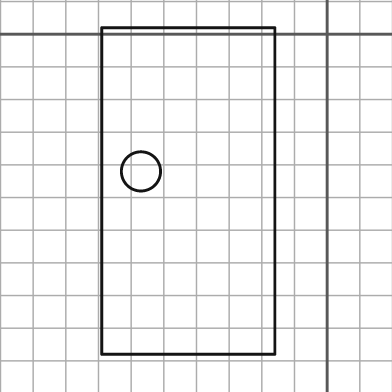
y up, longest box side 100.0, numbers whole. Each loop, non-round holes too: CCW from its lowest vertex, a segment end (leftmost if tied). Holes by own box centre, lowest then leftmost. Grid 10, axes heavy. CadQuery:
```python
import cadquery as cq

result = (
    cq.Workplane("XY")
    .moveTo(-69.0, -98.0)
    .lineTo(-16.0, -98.0)
    .lineTo(-16.0, 2.0)
    .lineTo(-69.0, 2.0)
    .close()
    .moveTo(-57.0, -42.0)
    .circle(6.0)
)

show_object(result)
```